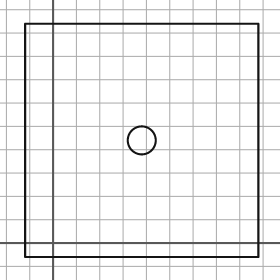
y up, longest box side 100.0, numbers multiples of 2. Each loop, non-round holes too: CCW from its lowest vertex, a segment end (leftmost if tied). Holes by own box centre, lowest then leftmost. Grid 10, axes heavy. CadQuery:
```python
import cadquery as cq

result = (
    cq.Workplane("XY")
    .moveTo(-12.0, -6.0)
    .lineTo(88.0, -6.0)
    .lineTo(88.0, 94.0)
    .lineTo(-12.0, 94.0)
    .close()
    .moveTo(38.0, 44.0)
    .circle(6.0)
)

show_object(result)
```